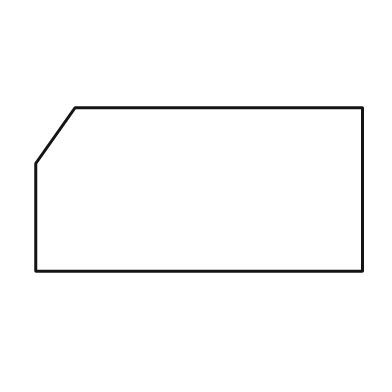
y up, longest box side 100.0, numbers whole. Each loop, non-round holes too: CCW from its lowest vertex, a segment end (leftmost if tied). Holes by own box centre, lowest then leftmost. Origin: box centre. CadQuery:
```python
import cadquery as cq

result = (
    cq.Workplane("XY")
    .moveTo(-50.0, -25.0)
    .lineTo(50.0, -25.0)
    .lineTo(50.0, 25.0)
    .lineTo(-38.0, 25.0)
    .lineTo(-50.0, 8.0)
    .close()
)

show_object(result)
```